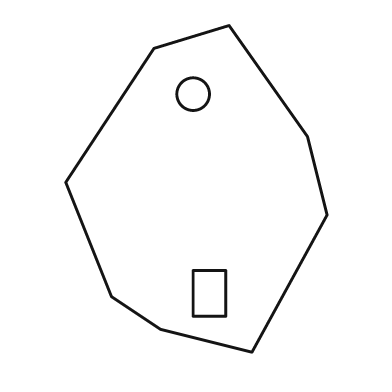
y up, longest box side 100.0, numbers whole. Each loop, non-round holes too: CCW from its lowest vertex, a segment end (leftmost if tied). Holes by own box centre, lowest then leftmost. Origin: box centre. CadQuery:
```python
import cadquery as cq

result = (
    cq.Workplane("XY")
    .moveTo(17.0, -50.0)
    .lineTo(40.0, -8.0)
    .lineTo(34.0, 16.0)
    .lineTo(10.0, 50.0)
    .lineTo(-13.0, 43.0)
    .lineTo(-40.0, 2.0)
    .lineTo(-26.0, -33.0)
    .lineTo(-11.0, -43.0)
    .close()
    .moveTo(-1.0, -39.0)
    .lineTo(9.0, -39.0)
    .lineTo(9.0, -25.0)
    .lineTo(-1.0, -25.0)
    .close()
    .moveTo(-1.0, 29.0)
    .circle(5.0)
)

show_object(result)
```